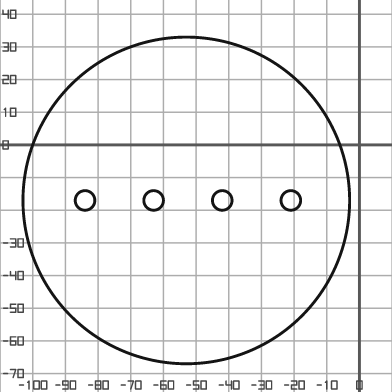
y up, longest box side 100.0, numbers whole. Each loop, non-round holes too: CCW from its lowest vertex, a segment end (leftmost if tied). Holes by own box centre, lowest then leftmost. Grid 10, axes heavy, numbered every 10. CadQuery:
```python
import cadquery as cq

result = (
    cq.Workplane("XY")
    .moveTo(-53.0, -17.0)
    .circle(50.0)
    .moveTo(-84.0, -17.0)
    .circle(3.0)
    .moveTo(-63.0, -17.0)
    .circle(3.0)
    .moveTo(-42.0, -17.0)
    .circle(3.0)
    .moveTo(-21.0, -17.0)
    .circle(3.0)
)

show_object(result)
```